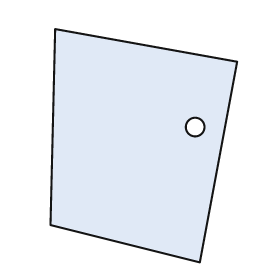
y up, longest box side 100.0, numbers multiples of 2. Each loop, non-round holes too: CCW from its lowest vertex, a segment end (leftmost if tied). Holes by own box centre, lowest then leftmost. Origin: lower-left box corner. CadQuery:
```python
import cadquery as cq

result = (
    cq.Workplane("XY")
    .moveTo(64.0, 0.0)
    .lineTo(80.0, 86.0)
    .lineTo(2.0, 100.0)
    .lineTo(0.0, 16.0)
    .close()
    .moveTo(62.0, 58.0)
    .circle(4.0)
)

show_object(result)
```